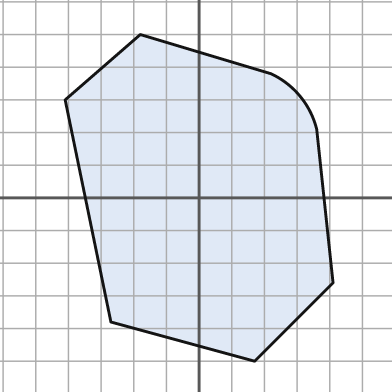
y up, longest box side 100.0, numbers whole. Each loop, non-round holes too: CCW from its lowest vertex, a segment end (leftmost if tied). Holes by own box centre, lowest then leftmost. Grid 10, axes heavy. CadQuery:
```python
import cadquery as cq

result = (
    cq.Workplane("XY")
    .moveTo(17.0, -50.0)
    .lineTo(41.0, -26.0)
    .lineTo(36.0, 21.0)
    .threePointArc((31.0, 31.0), (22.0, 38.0))
    .lineTo(-18.0, 50.0)
    .lineTo(-41.0, 30.0)
    .lineTo(-27.0, -38.0)
    .close()
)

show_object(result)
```